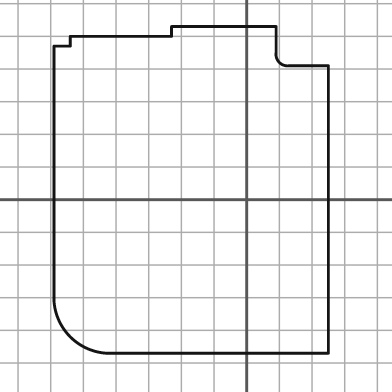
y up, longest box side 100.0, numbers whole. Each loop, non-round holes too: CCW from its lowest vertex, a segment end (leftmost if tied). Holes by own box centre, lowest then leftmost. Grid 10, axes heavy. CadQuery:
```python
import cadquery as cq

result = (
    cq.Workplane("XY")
    .moveTo(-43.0, -47.0)
    .lineTo(25.0, -47.0)
    .lineTo(25.0, 41.0)
    .lineTo(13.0, 41.0)
    .threePointArc((10.0, 42.0), (9.0, 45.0))
    .lineTo(9.0, 53.0)
    .lineTo(-23.0, 53.0)
    .lineTo(-23.0, 50.0)
    .lineTo(-54.0, 50.0)
    .lineTo(-54.0, 47.0)
    .lineTo(-59.0, 47.0)
    .lineTo(-59.0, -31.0)
    .threePointArc((-54.0, -42.0), (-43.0, -47.0))
    .close()
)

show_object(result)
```